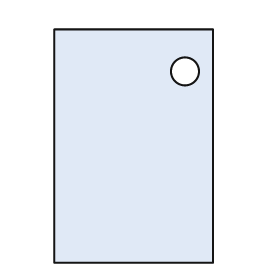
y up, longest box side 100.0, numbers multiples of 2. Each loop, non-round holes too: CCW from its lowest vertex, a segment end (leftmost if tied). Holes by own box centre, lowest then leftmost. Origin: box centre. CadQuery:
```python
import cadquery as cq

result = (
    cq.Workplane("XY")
    .moveTo(-34.0, -50.0)
    .lineTo(34.0, -50.0)
    .lineTo(34.0, 50.0)
    .lineTo(-34.0, 50.0)
    .close()
    .moveTo(22.0, 32.0)
    .circle(6.0)
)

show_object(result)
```